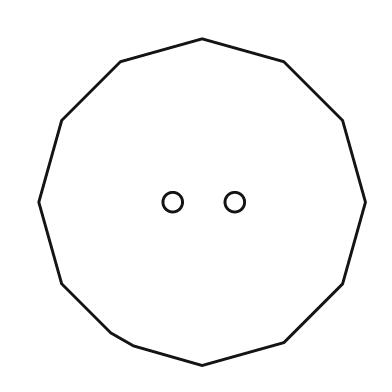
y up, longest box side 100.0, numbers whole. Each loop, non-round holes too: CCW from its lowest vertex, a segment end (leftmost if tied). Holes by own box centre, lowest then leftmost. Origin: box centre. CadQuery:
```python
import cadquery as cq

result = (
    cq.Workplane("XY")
    .moveTo(0.0, -50.0)
    .lineTo(25.0, -43.0)
    .lineTo(43.0, -25.0)
    .lineTo(50.0, 0.0)
    .lineTo(43.0, 25.0)
    .lineTo(25.0, 43.0)
    .lineTo(0.0, 50.0)
    .lineTo(-25.0, 43.0)
    .lineTo(-43.0, 25.0)
    .lineTo(-50.0, 0.0)
    .lineTo(-43.0, -25.0)
    .lineTo(-28.0, -40.0)
    .lineTo(-21.0, -44.0)
    .close()
    .moveTo(-9.0, 0.0)
    .circle(3.0)
    .moveTo(10.0, 0.0)
    .circle(3.0)
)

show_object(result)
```